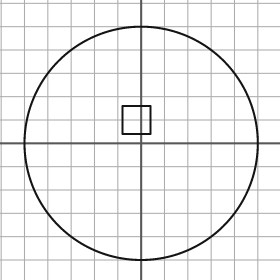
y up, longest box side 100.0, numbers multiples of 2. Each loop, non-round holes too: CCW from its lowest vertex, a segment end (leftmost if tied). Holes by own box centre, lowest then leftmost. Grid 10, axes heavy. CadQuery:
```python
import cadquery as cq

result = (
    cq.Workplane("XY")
    .moveTo(0.0, 0.0)
    .circle(50.0)
    .moveTo(-8.0, 4.0)
    .lineTo(4.0, 4.0)
    .lineTo(4.0, 16.0)
    .lineTo(-8.0, 16.0)
    .close()
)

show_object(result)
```